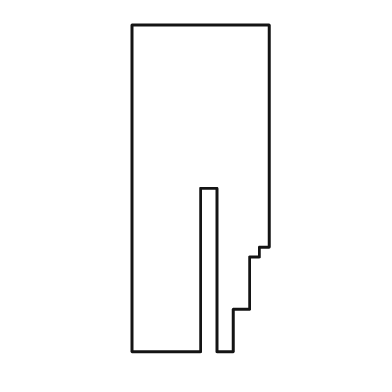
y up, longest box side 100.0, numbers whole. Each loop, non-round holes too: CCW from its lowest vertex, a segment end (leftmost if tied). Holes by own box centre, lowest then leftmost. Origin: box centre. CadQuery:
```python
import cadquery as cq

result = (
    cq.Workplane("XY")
    .moveTo(-21.0, -50.0)
    .lineTo(0.0, -50.0)
    .lineTo(0.0, 0.0)
    .lineTo(5.0, 0.0)
    .lineTo(5.0, -50.0)
    .lineTo(10.0, -50.0)
    .lineTo(10.0, -37.0)
    .lineTo(15.0, -37.0)
    .lineTo(15.0, -21.0)
    .lineTo(18.0, -21.0)
    .lineTo(18.0, -18.0)
    .lineTo(21.0, -18.0)
    .lineTo(21.0, 50.0)
    .lineTo(-21.0, 50.0)
    .close()
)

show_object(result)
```